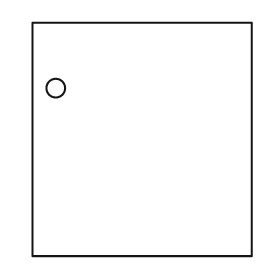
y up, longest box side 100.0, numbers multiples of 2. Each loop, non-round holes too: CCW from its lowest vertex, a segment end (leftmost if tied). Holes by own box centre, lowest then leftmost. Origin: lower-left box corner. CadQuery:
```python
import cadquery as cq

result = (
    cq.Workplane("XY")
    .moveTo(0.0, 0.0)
    .lineTo(94.0, 0.0)
    .lineTo(94.0, 100.0)
    .lineTo(0.0, 100.0)
    .close()
    .moveTo(10.0, 72.0)
    .circle(4.0)
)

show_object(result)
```